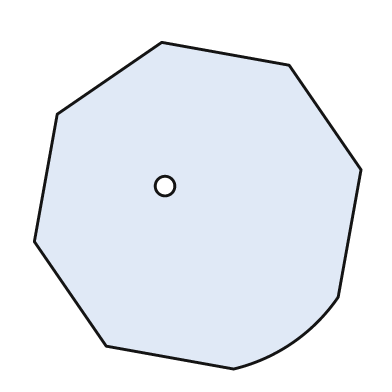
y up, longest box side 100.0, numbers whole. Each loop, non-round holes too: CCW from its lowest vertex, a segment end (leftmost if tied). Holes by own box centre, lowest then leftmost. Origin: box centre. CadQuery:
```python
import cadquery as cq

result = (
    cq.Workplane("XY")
    .moveTo(11.0, -50.0)
    .threePointArc((29.0, -42.0), (43.0, -28.0))
    .lineTo(50.0, 11.0)
    .lineTo(28.0, 43.0)
    .lineTo(-11.0, 50.0)
    .lineTo(-43.0, 28.0)
    .lineTo(-50.0, -11.0)
    .lineTo(-28.0, -43.0)
    .close()
    .moveTo(-10.0, 6.0)
    .circle(3.0)
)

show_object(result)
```